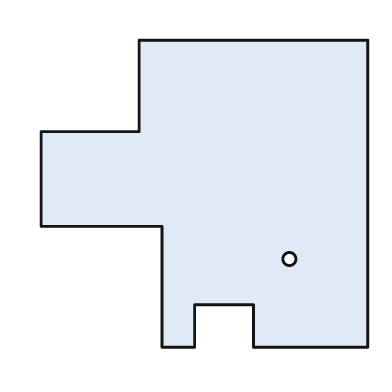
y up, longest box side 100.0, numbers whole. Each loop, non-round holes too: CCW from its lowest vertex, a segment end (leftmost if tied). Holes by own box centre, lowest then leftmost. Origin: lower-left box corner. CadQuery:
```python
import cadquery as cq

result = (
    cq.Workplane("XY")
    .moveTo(37.0, 0.0)
    .lineTo(47.0, 0.0)
    .lineTo(47.0, 13.0)
    .lineTo(65.0, 13.0)
    .lineTo(65.0, 0.0)
    .lineTo(100.0, 0.0)
    .lineTo(100.0, 94.0)
    .lineTo(30.0, 94.0)
    .lineTo(30.0, 66.0)
    .lineTo(0.0, 66.0)
    .lineTo(0.0, 37.0)
    .lineTo(37.0, 37.0)
    .close()
    .moveTo(76.0, 27.0)
    .circle(2.0)
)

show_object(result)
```